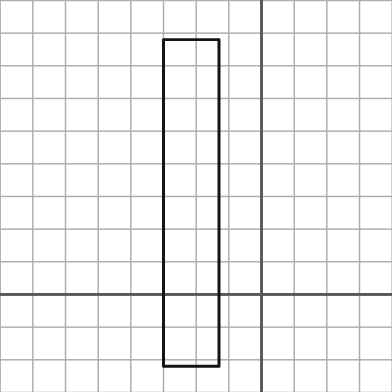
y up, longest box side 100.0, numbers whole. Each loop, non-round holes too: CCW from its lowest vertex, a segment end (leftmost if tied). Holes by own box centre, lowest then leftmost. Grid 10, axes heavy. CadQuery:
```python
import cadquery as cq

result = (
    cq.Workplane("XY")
    .moveTo(-30.0, -22.0)
    .lineTo(-13.0, -22.0)
    .lineTo(-13.0, 78.0)
    .lineTo(-30.0, 78.0)
    .close()
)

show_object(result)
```